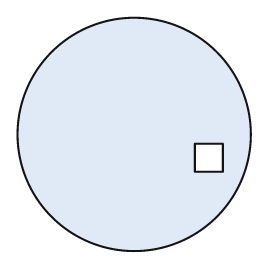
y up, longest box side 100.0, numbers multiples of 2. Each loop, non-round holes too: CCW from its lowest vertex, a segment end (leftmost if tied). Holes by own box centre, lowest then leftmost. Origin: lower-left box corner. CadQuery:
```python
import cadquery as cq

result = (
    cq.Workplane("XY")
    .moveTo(50.0, 50.0)
    .circle(50.0)
    .moveTo(76.0, 34.0)
    .lineTo(88.0, 34.0)
    .lineTo(88.0, 46.0)
    .lineTo(76.0, 46.0)
    .close()
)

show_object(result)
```